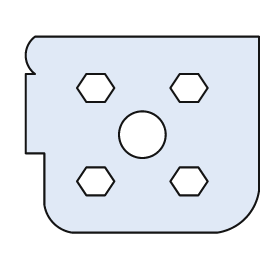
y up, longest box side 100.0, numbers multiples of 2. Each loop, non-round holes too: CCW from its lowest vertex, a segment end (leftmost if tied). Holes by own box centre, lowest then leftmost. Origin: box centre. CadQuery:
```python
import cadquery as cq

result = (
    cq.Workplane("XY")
    .moveTo(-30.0, -42.0)
    .lineTo(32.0, -42.0)
    .threePointArc((44.0, -36.0), (50.0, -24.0))
    .lineTo(50.0, 42.0)
    .lineTo(-46.0, 42.0)
    .threePointArc((-50.0, 34.0), (-46.0, 26.0))
    .lineTo(-50.0, 26.0)
    .lineTo(-50.0, -8.0)
    .lineTo(-42.0, -8.0)
    .lineTo(-42.0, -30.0)
    .threePointArc((-38.0, -38.0), (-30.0, -42.0))
    .close()
    .moveTo(-24.0, -26.0)
    .lineTo(-16.0, -26.0)
    .lineTo(-12.0, -20.0)
    .lineTo(-16.0, -14.0)
    .lineTo(-24.0, -14.0)
    .lineTo(-28.0, -20.0)
    .close()
    .moveTo(16.0, -26.0)
    .lineTo(24.0, -26.0)
    .lineTo(28.0, -20.0)
    .lineTo(24.0, -14.0)
    .lineTo(16.0, -14.0)
    .lineTo(12.0, -20.0)
    .close()
    .moveTo(0.0, 0.0)
    .circle(10.0)
    .moveTo(-24.0, 14.0)
    .lineTo(-16.0, 14.0)
    .lineTo(-12.0, 20.0)
    .lineTo(-16.0, 26.0)
    .lineTo(-24.0, 26.0)
    .lineTo(-28.0, 20.0)
    .close()
    .moveTo(16.0, 14.0)
    .lineTo(24.0, 14.0)
    .lineTo(28.0, 20.0)
    .lineTo(24.0, 26.0)
    .lineTo(16.0, 26.0)
    .lineTo(12.0, 20.0)
    .close()
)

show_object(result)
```